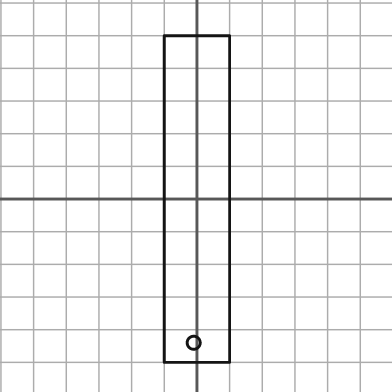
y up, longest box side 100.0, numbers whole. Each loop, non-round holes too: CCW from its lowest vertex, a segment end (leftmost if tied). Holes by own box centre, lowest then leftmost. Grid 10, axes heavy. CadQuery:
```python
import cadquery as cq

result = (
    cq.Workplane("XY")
    .moveTo(-10.0, -50.0)
    .lineTo(10.0, -50.0)
    .lineTo(10.0, 50.0)
    .lineTo(-10.0, 50.0)
    .close()
    .moveTo(-1.0, -44.0)
    .circle(2.0)
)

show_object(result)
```